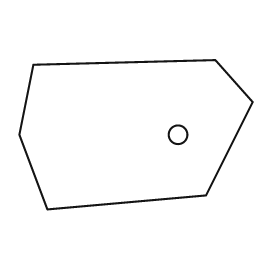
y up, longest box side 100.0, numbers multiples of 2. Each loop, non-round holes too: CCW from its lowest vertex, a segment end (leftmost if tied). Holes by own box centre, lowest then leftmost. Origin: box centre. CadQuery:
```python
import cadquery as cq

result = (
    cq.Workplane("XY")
    .moveTo(-38.0, -32.0)
    .lineTo(30.0, -26.0)
    .lineTo(50.0, 14.0)
    .lineTo(34.0, 32.0)
    .lineTo(-44.0, 30.0)
    .lineTo(-50.0, 0.0)
    .close()
    .moveTo(18.0, 0.0)
    .circle(4.0)
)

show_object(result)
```